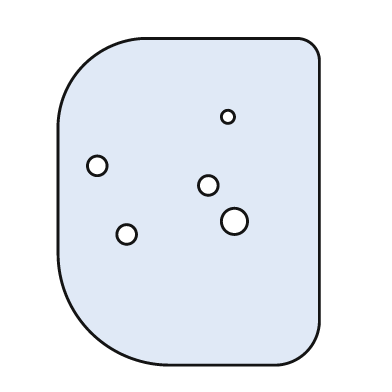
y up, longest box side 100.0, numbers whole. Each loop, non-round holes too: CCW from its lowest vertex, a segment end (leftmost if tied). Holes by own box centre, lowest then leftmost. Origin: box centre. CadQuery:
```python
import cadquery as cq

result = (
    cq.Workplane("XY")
    .moveTo(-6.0, -50.0)
    .lineTo(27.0, -50.0)
    .threePointArc((36.0, -46.0), (40.0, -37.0))
    .lineTo(40.0, 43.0)
    .threePointArc((38.0, 48.0), (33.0, 50.0))
    .lineTo(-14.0, 50.0)
    .threePointArc((-32.0, 42.0), (-40.0, 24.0))
    .lineTo(-40.0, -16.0)
    .threePointArc((-30.0, -40.0), (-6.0, -50.0))
    .close()
    .moveTo(-19.0, -10.0)
    .circle(3.0)
    .moveTo(14.0, -6.0)
    .circle(4.0)
    .moveTo(6.0, 5.0)
    .circle(3.0)
    .moveTo(-28.0, 11.0)
    .circle(3.0)
    .moveTo(12.0, 26.0)
    .circle(2.0)
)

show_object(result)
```